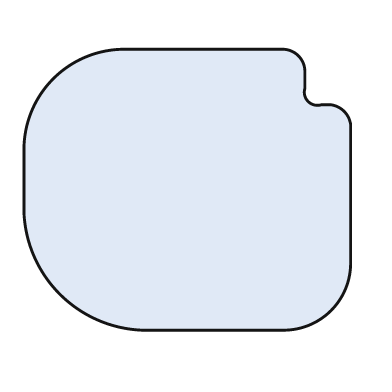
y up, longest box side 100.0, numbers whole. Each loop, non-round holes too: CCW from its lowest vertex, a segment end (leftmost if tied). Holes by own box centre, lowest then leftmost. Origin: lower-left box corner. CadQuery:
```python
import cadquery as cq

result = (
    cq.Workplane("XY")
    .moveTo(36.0, 0.0)
    .lineTo(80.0, 0.0)
    .threePointArc((94.0, 6.0), (100.0, 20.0))
    .lineTo(100.0, 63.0)
    .threePointArc((98.0, 67.0), (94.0, 69.0))
    .lineTo(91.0, 69.0)
    .threePointArc((87.0, 70.0), (86.0, 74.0))
    .lineTo(86.0, 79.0)
    .threePointArc((84.0, 84.0), (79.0, 86.0))
    .lineTo(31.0, 86.0)
    .threePointArc((9.0, 77.0), (0.0, 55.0))
    .lineTo(0.0, 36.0)
    .threePointArc((11.0, 11.0), (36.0, 0.0))
    .close()
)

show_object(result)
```